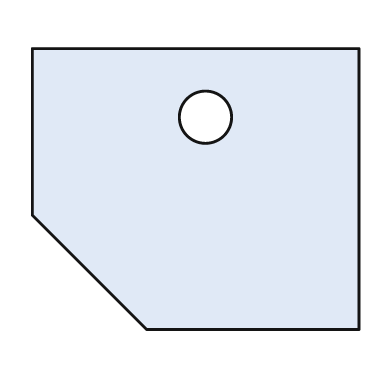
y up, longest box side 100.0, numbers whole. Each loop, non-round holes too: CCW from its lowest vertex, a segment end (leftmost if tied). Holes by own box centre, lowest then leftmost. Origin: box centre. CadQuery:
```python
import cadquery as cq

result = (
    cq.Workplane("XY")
    .moveTo(-15.0, -43.0)
    .lineTo(50.0, -43.0)
    .lineTo(50.0, 43.0)
    .lineTo(-50.0, 43.0)
    .lineTo(-50.0, -8.0)
    .close()
    .moveTo(3.0, 22.0)
    .circle(8.0)
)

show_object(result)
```